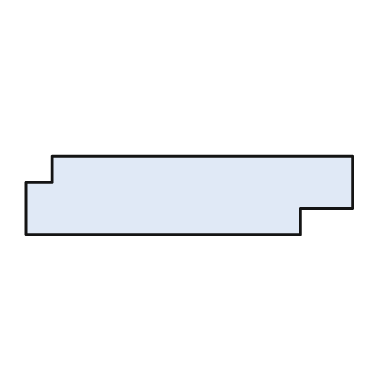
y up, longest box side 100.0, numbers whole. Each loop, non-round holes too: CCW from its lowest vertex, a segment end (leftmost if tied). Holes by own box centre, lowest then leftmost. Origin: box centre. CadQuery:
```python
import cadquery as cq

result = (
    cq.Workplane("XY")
    .moveTo(-50.0, -12.0)
    .lineTo(34.0, -12.0)
    .lineTo(34.0, -4.0)
    .lineTo(50.0, -4.0)
    .lineTo(50.0, 12.0)
    .lineTo(-42.0, 12.0)
    .lineTo(-42.0, 4.0)
    .lineTo(-50.0, 4.0)
    .close()
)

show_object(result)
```